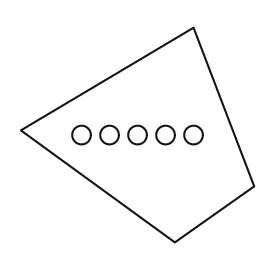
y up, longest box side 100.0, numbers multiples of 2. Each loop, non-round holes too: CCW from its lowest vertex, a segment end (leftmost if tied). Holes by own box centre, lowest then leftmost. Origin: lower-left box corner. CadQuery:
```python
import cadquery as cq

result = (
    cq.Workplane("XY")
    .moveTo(66.0, 0.0)
    .lineTo(100.0, 24.0)
    .lineTo(74.0, 92.0)
    .lineTo(0.0, 48.0)
    .close()
    .moveTo(26.0, 46.0)
    .circle(4.0)
    .moveTo(38.0, 46.0)
    .circle(4.0)
    .moveTo(50.0, 46.0)
    .circle(4.0)
    .moveTo(62.0, 46.0)
    .circle(4.0)
    .moveTo(74.0, 46.0)
    .circle(4.0)
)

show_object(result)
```